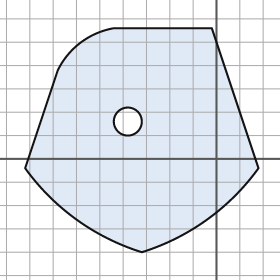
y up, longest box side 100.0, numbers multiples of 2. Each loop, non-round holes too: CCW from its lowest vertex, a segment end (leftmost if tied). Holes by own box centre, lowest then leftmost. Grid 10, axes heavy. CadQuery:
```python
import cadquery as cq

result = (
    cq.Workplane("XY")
    .moveTo(-32.0, -40.0)
    .threePointArc((-4.0, -26.0), (18.0, -4.0))
    .lineTo(-2.0, 56.0)
    .lineTo(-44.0, 56.0)
    .threePointArc((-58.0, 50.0), (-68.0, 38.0))
    .lineTo(-82.0, -4.0)
    .threePointArc((-60.0, -26.0), (-32.0, -40.0))
    .close()
    .moveTo(-38.0, 16.0)
    .circle(6.0)
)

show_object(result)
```